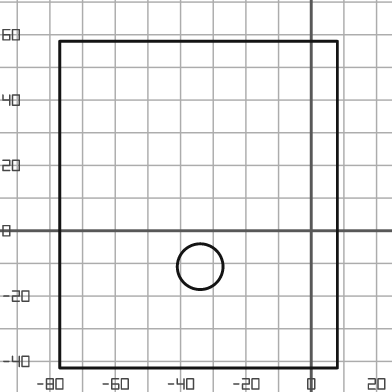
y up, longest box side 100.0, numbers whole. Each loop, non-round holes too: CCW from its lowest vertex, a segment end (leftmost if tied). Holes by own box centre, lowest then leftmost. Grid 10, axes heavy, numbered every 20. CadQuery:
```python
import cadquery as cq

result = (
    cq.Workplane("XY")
    .moveTo(-77.0, -42.0)
    .lineTo(8.0, -42.0)
    .lineTo(8.0, 58.0)
    .lineTo(-77.0, 58.0)
    .close()
    .moveTo(-34.0, -11.0)
    .circle(7.0)
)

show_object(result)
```